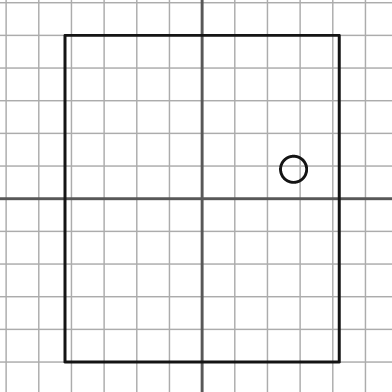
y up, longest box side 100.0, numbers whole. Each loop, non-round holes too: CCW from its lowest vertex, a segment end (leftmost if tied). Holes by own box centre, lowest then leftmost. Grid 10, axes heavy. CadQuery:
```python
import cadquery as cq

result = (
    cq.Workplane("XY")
    .moveTo(-42.0, -50.0)
    .lineTo(42.0, -50.0)
    .lineTo(42.0, 50.0)
    .lineTo(-42.0, 50.0)
    .close()
    .moveTo(28.0, 9.0)
    .circle(4.0)
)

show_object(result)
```